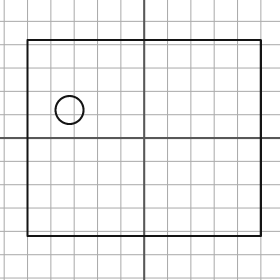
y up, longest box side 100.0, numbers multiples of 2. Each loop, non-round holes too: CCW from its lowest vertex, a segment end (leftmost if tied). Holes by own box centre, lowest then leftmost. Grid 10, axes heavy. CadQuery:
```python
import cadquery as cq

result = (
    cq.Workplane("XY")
    .moveTo(-50.0, -42.0)
    .lineTo(50.0, -42.0)
    .lineTo(50.0, 42.0)
    .lineTo(-50.0, 42.0)
    .close()
    .moveTo(-32.0, 12.0)
    .circle(6.0)
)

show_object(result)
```